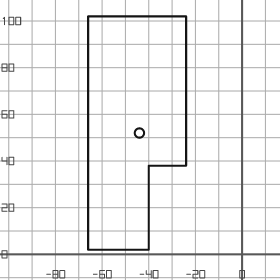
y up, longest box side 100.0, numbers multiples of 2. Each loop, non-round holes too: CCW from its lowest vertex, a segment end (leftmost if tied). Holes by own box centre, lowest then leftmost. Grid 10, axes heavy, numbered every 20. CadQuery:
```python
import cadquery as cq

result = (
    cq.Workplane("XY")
    .moveTo(-66.0, 2.0)
    .lineTo(-40.0, 2.0)
    .lineTo(-40.0, 38.0)
    .lineTo(-24.0, 38.0)
    .lineTo(-24.0, 102.0)
    .lineTo(-66.0, 102.0)
    .close()
    .moveTo(-44.0, 52.0)
    .circle(2.0)
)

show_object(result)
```